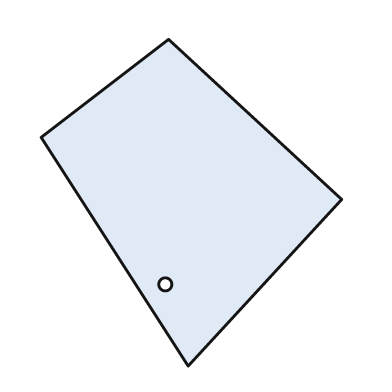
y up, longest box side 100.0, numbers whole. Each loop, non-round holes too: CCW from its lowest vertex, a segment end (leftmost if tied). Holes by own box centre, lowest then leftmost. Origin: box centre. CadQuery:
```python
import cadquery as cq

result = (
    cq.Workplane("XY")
    .moveTo(-1.0, -50.0)
    .lineTo(46.0, 1.0)
    .lineTo(-7.0, 50.0)
    .lineTo(-46.0, 20.0)
    .close()
    .moveTo(-8.0, -25.0)
    .circle(2.0)
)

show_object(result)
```